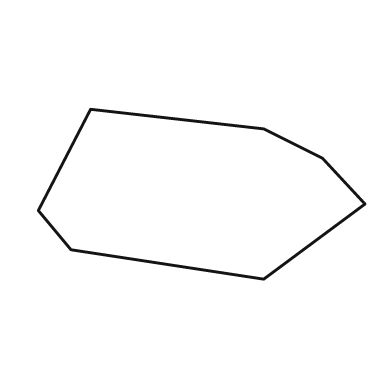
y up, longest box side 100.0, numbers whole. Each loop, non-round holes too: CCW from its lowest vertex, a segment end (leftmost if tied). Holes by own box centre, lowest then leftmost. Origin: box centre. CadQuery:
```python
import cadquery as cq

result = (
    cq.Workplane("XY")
    .moveTo(19.0, -26.0)
    .lineTo(50.0, -3.0)
    .lineTo(37.0, 11.0)
    .lineTo(19.0, 20.0)
    .lineTo(-34.0, 26.0)
    .lineTo(-50.0, -5.0)
    .lineTo(-40.0, -17.0)
    .close()
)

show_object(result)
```